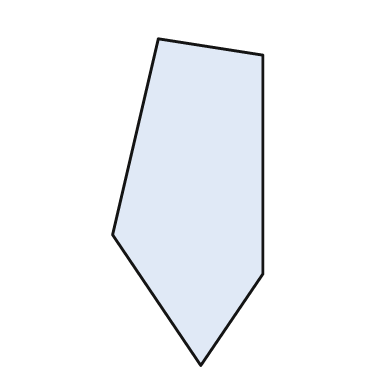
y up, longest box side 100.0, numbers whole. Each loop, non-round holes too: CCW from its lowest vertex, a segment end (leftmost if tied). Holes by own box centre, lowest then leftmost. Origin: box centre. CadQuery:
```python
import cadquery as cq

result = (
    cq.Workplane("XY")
    .moveTo(4.0, -50.0)
    .lineTo(23.0, -22.0)
    .lineTo(23.0, 45.0)
    .lineTo(-9.0, 50.0)
    .lineTo(-23.0, -10.0)
    .close()
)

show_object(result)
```